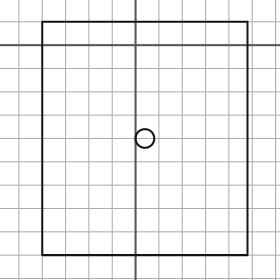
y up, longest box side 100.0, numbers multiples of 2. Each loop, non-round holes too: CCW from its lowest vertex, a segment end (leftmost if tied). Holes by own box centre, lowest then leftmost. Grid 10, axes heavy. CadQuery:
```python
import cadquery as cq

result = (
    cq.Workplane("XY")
    .moveTo(-40.0, -90.0)
    .lineTo(48.0, -90.0)
    .lineTo(48.0, 10.0)
    .lineTo(-40.0, 10.0)
    .close()
    .moveTo(4.0, -40.0)
    .circle(4.0)
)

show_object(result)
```